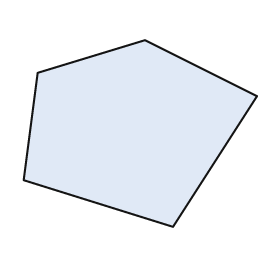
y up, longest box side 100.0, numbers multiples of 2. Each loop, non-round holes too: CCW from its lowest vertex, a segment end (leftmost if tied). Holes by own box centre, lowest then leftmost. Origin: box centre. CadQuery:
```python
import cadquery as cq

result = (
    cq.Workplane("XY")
    .moveTo(14.0, -40.0)
    .lineTo(50.0, 16.0)
    .lineTo(2.0, 40.0)
    .lineTo(-44.0, 26.0)
    .lineTo(-50.0, -20.0)
    .close()
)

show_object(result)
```